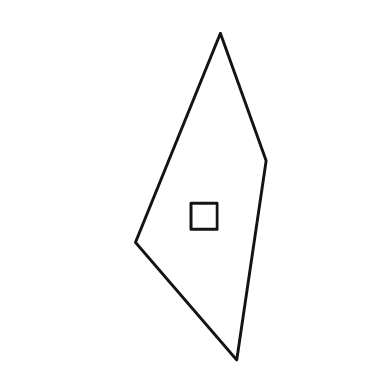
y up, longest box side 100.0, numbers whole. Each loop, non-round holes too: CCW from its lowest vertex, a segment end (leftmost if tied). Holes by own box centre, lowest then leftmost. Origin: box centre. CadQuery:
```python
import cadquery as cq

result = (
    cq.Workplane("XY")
    .moveTo(11.0, -50.0)
    .lineTo(20.0, 11.0)
    .lineTo(6.0, 50.0)
    .lineTo(-20.0, -14.0)
    .close()
    .moveTo(-3.0, -10.0)
    .lineTo(5.0, -10.0)
    .lineTo(5.0, -2.0)
    .lineTo(-3.0, -2.0)
    .close()
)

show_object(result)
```